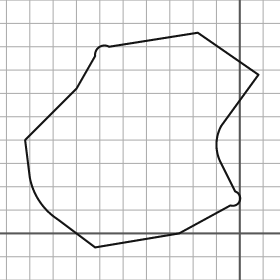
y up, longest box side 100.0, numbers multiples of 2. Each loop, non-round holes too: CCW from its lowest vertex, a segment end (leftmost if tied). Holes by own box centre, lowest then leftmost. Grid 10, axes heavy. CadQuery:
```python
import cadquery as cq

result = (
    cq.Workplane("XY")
    .moveTo(-62.0, -6.0)
    .lineTo(-26.0, 0.0)
    .lineTo(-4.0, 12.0)
    .threePointArc((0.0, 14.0), (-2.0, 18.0))
    .lineTo(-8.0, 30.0)
    .threePointArc((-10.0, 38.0), (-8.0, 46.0))
    .lineTo(8.0, 68.0)
    .lineTo(-18.0, 86.0)
    .lineTo(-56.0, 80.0)
    .threePointArc((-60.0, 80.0), (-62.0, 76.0))
    .lineTo(-70.0, 62.0)
    .lineTo(-92.0, 40.0)
    .lineTo(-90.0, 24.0)
    .threePointArc((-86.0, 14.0), (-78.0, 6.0))
    .close()
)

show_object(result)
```